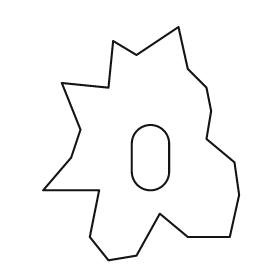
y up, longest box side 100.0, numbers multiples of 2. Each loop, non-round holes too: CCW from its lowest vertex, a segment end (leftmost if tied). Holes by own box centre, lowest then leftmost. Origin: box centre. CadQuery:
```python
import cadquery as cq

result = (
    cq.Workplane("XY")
    .moveTo(-14.0, -50.0)
    .lineTo(-2.0, -48.0)
    .lineTo(8.0, -30.0)
    .lineTo(20.0, -40.0)
    .lineTo(38.0, -40.0)
    .lineTo(42.0, -22.0)
    .lineTo(40.0, -8.0)
    .lineTo(28.0, 2.0)
    .lineTo(30.0, 14.0)
    .lineTo(28.0, 24.0)
    .lineTo(20.0, 32.0)
    .lineTo(16.0, 50.0)
    .lineTo(-2.0, 38.0)
    .lineTo(-12.0, 44.0)
    .lineTo(-14.0, 24.0)
    .lineTo(-34.0, 26.0)
    .lineTo(-26.0, 6.0)
    .lineTo(-30.0, -6.0)
    .lineTo(-42.0, -20.0)
    .lineTo(-18.0, -20.0)
    .lineTo(-22.0, -40.0)
    .close()
    .moveTo(-4.0, -12.0)
    .threePointArc((4.0, -20.0), (12.0, -12.0))
    .lineTo(12.0, 0.0)
    .threePointArc((4.0, 8.0), (-4.0, 0.0))
    .close()
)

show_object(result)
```